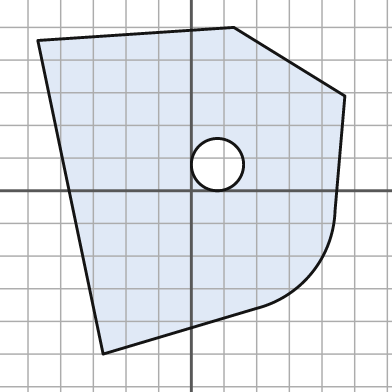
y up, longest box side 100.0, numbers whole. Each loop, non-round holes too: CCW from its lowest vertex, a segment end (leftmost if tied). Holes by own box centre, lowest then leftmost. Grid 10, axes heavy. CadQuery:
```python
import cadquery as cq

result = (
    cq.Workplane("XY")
    .moveTo(-27.0, -50.0)
    .lineTo(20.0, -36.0)
    .threePointArc((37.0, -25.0), (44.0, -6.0))
    .lineTo(47.0, 29.0)
    .lineTo(13.0, 50.0)
    .lineTo(-47.0, 46.0)
    .close()
    .moveTo(8.0, 8.0)
    .circle(8.0)
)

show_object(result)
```